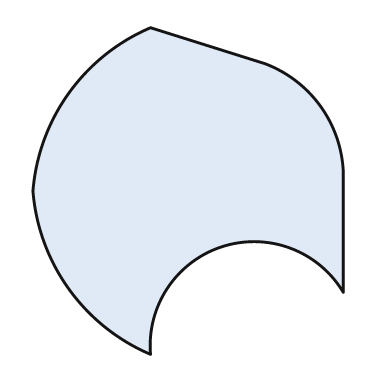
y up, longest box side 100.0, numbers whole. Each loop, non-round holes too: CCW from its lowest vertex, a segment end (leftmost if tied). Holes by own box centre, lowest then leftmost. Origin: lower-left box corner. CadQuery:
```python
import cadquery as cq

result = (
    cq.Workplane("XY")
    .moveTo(36.0, 0.0)
    .threePointArc((58.0, 33.0), (95.0, 19.0))
    .lineTo(95.0, 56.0)
    .threePointArc((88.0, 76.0), (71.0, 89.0))
    .lineTo(36.0, 100.0)
    .threePointArc((11.0, 80.0), (0.0, 50.0))
    .threePointArc((11.0, 20.0), (36.0, 0.0))
    .close()
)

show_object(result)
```